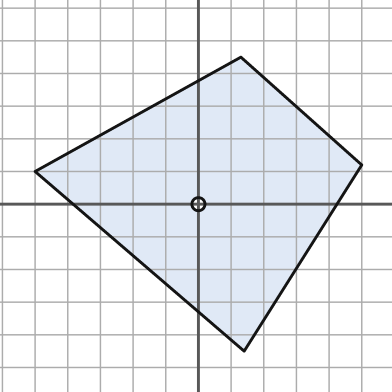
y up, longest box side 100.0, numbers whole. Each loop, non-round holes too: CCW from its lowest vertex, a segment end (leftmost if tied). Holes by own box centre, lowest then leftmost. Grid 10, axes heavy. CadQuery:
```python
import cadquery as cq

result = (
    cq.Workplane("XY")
    .moveTo(14.0, -45.0)
    .lineTo(50.0, 12.0)
    .lineTo(13.0, 45.0)
    .lineTo(-50.0, 10.0)
    .close()
    .moveTo(0.0, 0.0)
    .circle(2.0)
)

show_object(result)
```